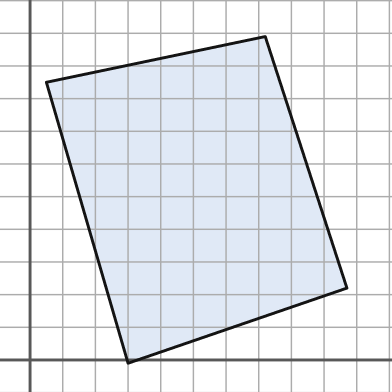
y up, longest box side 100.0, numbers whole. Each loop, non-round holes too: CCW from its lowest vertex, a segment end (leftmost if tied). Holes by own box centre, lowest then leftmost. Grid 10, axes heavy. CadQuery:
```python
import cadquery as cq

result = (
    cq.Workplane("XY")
    .moveTo(30.0, -1.0)
    .lineTo(97.0, 22.0)
    .lineTo(72.0, 99.0)
    .lineTo(5.0, 85.0)
    .close()
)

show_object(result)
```